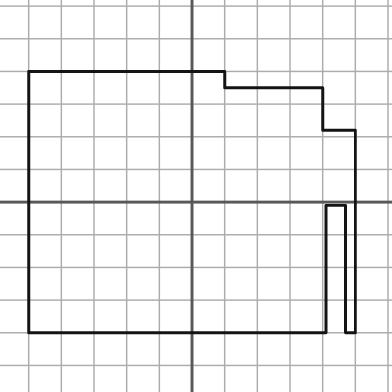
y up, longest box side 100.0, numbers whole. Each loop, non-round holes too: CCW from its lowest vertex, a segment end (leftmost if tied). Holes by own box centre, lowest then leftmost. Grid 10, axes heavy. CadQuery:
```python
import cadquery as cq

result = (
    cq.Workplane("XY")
    .moveTo(-50.0, -40.0)
    .lineTo(41.0, -40.0)
    .lineTo(41.0, -1.0)
    .lineTo(47.0, -1.0)
    .lineTo(47.0, -40.0)
    .lineTo(50.0, -40.0)
    .lineTo(50.0, 22.0)
    .lineTo(40.0, 22.0)
    .lineTo(40.0, 35.0)
    .lineTo(10.0, 35.0)
    .lineTo(10.0, 40.0)
    .lineTo(-50.0, 40.0)
    .close()
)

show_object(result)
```